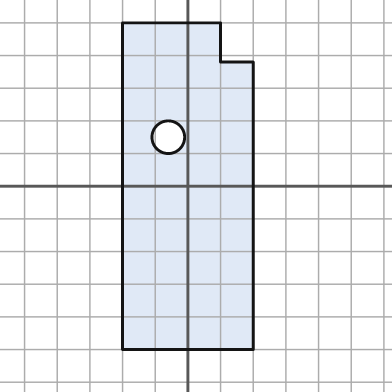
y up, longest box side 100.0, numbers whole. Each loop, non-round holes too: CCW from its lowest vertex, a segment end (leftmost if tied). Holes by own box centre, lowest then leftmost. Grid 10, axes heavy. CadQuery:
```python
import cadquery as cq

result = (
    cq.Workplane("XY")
    .moveTo(-20.0, -50.0)
    .lineTo(20.0, -50.0)
    .lineTo(20.0, 38.0)
    .lineTo(10.0, 38.0)
    .lineTo(10.0, 50.0)
    .lineTo(-20.0, 50.0)
    .close()
    .moveTo(-6.0, 15.0)
    .circle(5.0)
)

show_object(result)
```